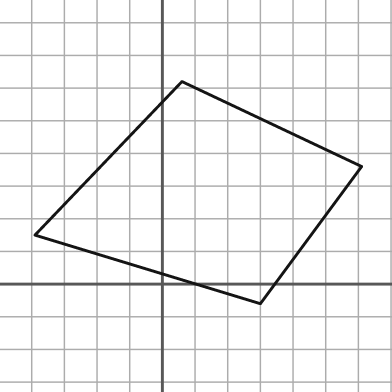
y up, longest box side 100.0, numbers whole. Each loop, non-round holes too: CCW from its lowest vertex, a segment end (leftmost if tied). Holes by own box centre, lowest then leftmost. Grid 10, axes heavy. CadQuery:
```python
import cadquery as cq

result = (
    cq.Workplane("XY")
    .moveTo(30.0, -6.0)
    .lineTo(61.0, 36.0)
    .lineTo(6.0, 62.0)
    .lineTo(-39.0, 15.0)
    .close()
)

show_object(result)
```